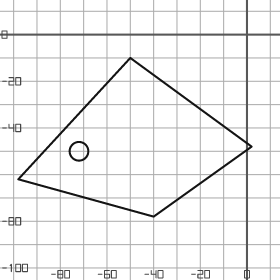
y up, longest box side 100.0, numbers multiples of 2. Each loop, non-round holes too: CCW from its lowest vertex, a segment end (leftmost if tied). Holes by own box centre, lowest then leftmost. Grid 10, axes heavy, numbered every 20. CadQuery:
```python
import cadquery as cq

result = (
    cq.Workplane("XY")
    .moveTo(-40.0, -78.0)
    .lineTo(2.0, -48.0)
    .lineTo(-50.0, -10.0)
    .lineTo(-98.0, -62.0)
    .close()
    .moveTo(-72.0, -50.0)
    .circle(4.0)
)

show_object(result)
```